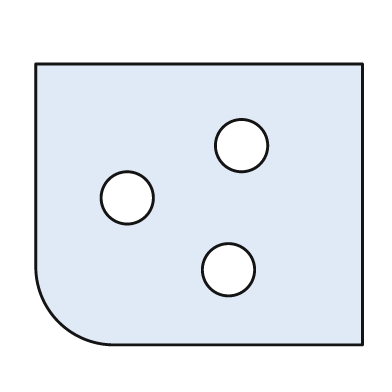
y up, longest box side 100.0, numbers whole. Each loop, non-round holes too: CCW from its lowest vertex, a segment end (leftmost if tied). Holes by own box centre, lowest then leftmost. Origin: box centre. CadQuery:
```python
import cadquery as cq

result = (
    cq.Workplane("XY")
    .moveTo(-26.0, -43.0)
    .lineTo(50.0, -43.0)
    .lineTo(50.0, 43.0)
    .lineTo(-50.0, 43.0)
    .lineTo(-50.0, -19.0)
    .threePointArc((-43.0, -36.0), (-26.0, -43.0))
    .close()
    .moveTo(9.0, -20.0)
    .circle(8.0)
    .moveTo(-22.0, 2.0)
    .circle(8.0)
    .moveTo(13.0, 18.0)
    .circle(8.0)
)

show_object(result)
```